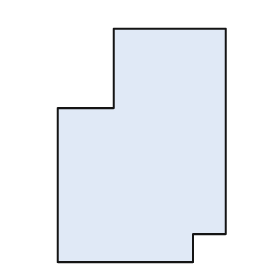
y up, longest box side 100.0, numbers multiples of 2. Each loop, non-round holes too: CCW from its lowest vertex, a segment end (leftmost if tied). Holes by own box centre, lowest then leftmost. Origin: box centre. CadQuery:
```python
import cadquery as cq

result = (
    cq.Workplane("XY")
    .moveTo(-36.0, -50.0)
    .lineTo(22.0, -50.0)
    .lineTo(22.0, -38.0)
    .lineTo(36.0, -38.0)
    .lineTo(36.0, 50.0)
    .lineTo(-12.0, 50.0)
    .lineTo(-12.0, 16.0)
    .lineTo(-36.0, 16.0)
    .close()
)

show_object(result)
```